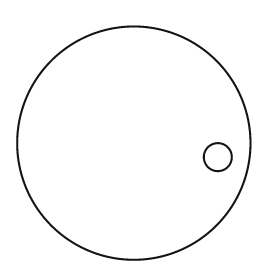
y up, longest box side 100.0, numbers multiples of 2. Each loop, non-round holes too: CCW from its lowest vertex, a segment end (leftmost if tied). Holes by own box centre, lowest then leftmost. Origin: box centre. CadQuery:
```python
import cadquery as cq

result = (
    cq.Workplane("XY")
    .moveTo(0.0, 0.0)
    .circle(50.0)
    .moveTo(36.0, -6.0)
    .circle(6.0)
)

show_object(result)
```